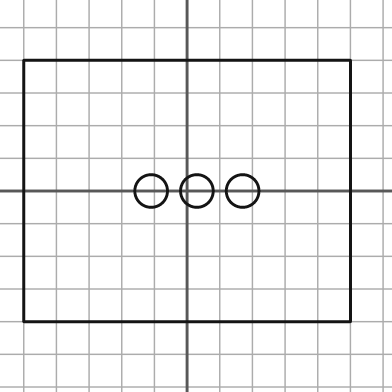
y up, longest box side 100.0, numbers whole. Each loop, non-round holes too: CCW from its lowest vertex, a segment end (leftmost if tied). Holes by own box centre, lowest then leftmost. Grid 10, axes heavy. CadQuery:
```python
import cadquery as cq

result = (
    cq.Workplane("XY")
    .moveTo(-50.0, -40.0)
    .lineTo(50.0, -40.0)
    .lineTo(50.0, 40.0)
    .lineTo(-50.0, 40.0)
    .close()
    .moveTo(-11.0, 0.0)
    .circle(5.0)
    .moveTo(3.0, 0.0)
    .circle(5.0)
    .moveTo(17.0, 0.0)
    .circle(5.0)
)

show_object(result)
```